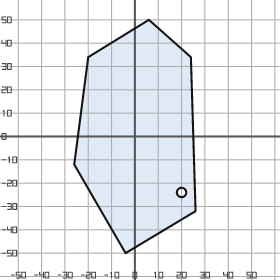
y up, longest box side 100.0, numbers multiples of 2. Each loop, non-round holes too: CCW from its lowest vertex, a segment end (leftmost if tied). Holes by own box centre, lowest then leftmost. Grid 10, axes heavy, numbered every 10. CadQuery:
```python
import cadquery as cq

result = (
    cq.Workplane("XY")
    .moveTo(-4.0, -50.0)
    .lineTo(26.0, -32.0)
    .lineTo(24.0, 34.0)
    .lineTo(6.0, 50.0)
    .lineTo(-20.0, 34.0)
    .lineTo(-26.0, -12.0)
    .close()
    .moveTo(20.0, -24.0)
    .circle(2.0)
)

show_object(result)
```